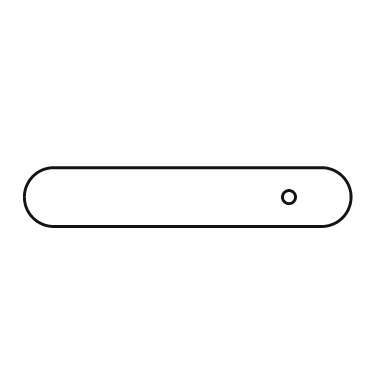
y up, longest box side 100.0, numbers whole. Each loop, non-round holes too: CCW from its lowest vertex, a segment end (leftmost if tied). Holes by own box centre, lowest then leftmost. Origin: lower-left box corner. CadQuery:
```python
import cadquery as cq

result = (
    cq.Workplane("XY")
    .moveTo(9.0, 0.0)
    .lineTo(91.0, 0.0)
    .threePointArc((100.0, 9.0), (91.0, 18.0))
    .lineTo(9.0, 18.0)
    .threePointArc((0.0, 9.0), (9.0, 0.0))
    .close()
    .moveTo(81.0, 9.0)
    .circle(2.0)
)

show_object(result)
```